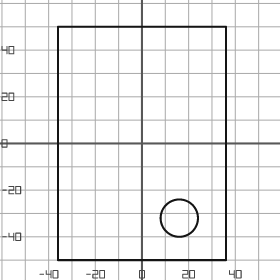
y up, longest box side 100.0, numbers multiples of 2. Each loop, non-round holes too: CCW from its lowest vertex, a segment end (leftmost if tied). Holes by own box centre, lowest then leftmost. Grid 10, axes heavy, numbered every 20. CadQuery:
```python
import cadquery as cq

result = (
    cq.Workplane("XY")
    .moveTo(-36.0, -50.0)
    .lineTo(36.0, -50.0)
    .lineTo(36.0, 50.0)
    .lineTo(-36.0, 50.0)
    .close()
    .moveTo(16.0, -32.0)
    .circle(8.0)
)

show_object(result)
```